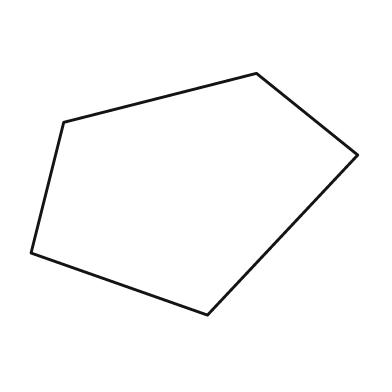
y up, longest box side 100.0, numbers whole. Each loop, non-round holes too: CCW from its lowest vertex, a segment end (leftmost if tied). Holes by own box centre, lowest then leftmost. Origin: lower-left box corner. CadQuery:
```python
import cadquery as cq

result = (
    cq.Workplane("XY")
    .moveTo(54.0, 0.0)
    .lineTo(100.0, 49.0)
    .lineTo(69.0, 74.0)
    .lineTo(10.0, 59.0)
    .lineTo(0.0, 19.0)
    .close()
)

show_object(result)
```